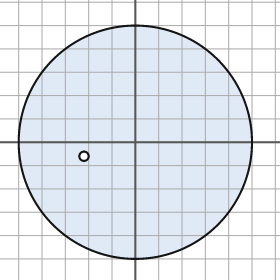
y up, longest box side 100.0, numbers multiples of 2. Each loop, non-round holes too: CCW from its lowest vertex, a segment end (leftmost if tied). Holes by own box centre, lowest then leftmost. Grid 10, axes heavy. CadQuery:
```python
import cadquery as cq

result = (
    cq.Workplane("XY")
    .moveTo(0.0, 0.0)
    .circle(50.0)
    .moveTo(-22.0, -6.0)
    .circle(2.0)
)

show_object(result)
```